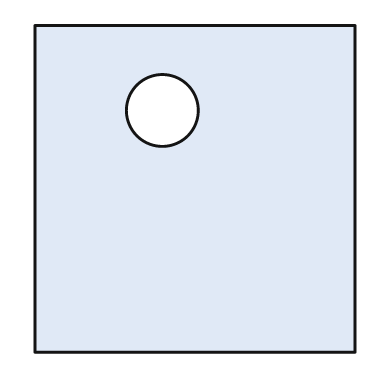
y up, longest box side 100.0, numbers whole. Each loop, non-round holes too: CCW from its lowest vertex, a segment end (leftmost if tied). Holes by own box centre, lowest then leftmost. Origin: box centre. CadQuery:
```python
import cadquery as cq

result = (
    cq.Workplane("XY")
    .moveTo(-49.0, -50.0)
    .lineTo(49.0, -50.0)
    .lineTo(49.0, 50.0)
    .lineTo(-49.0, 50.0)
    .close()
    .moveTo(-10.0, 24.0)
    .circle(11.0)
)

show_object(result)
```